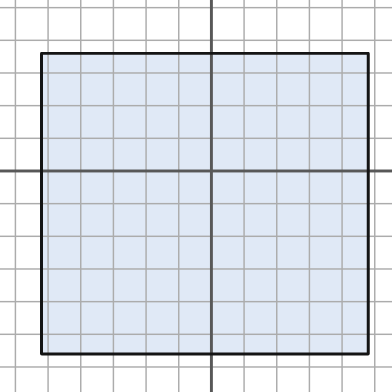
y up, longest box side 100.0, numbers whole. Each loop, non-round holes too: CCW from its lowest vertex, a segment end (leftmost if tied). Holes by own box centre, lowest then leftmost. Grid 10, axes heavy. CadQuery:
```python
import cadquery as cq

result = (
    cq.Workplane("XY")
    .moveTo(-52.0, -56.0)
    .lineTo(48.0, -56.0)
    .lineTo(48.0, 36.0)
    .lineTo(-52.0, 36.0)
    .close()
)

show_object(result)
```